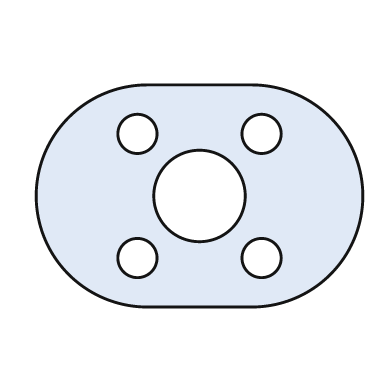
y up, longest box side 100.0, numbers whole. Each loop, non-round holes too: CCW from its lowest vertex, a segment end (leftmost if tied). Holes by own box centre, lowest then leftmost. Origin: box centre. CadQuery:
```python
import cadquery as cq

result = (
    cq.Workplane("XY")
    .moveTo(-16.0, -34.0)
    .lineTo(16.0, -34.0)
    .threePointArc((50.0, 0.0), (16.0, 34.0))
    .lineTo(-16.0, 34.0)
    .threePointArc((-50.0, 0.0), (-16.0, -34.0))
    .close()
    .moveTo(-19.0, -19.0)
    .circle(6.0)
    .moveTo(19.0, -19.0)
    .circle(6.0)
    .moveTo(0.0, 0.0)
    .circle(14.0)
    .moveTo(-19.0, 19.0)
    .circle(6.0)
    .moveTo(19.0, 19.0)
    .circle(6.0)
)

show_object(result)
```